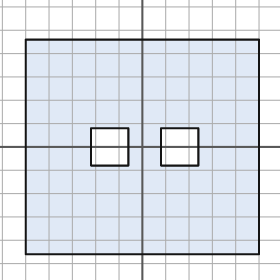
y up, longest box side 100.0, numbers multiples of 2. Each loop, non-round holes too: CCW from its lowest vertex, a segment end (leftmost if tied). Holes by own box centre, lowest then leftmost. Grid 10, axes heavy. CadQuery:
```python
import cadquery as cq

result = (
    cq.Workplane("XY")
    .moveTo(-50.0, -46.0)
    .lineTo(50.0, -46.0)
    .lineTo(50.0, 46.0)
    .lineTo(-50.0, 46.0)
    .close()
    .moveTo(-22.0, -8.0)
    .lineTo(-6.0, -8.0)
    .lineTo(-6.0, 8.0)
    .lineTo(-22.0, 8.0)
    .close()
    .moveTo(8.0, -8.0)
    .lineTo(24.0, -8.0)
    .lineTo(24.0, 8.0)
    .lineTo(8.0, 8.0)
    .close()
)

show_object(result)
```